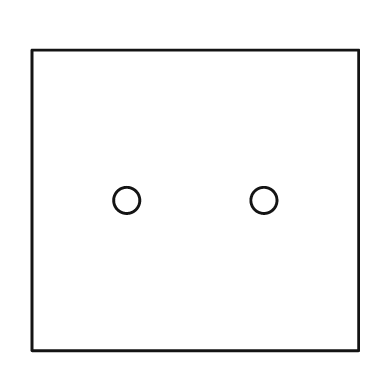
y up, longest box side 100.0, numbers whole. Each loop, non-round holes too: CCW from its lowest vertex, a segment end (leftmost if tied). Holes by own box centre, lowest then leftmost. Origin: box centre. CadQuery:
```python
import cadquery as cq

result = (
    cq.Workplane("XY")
    .moveTo(-50.0, -46.0)
    .lineTo(50.0, -46.0)
    .lineTo(50.0, 46.0)
    .lineTo(-50.0, 46.0)
    .close()
    .moveTo(-21.0, 0.0)
    .circle(4.0)
    .moveTo(21.0, 0.0)
    .circle(4.0)
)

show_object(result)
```